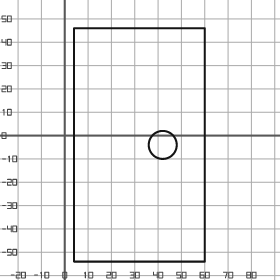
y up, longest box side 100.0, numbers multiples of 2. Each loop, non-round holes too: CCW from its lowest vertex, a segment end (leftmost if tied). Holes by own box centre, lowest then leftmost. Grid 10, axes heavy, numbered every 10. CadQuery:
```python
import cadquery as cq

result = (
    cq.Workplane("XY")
    .moveTo(4.0, -54.0)
    .lineTo(60.0, -54.0)
    .lineTo(60.0, 46.0)
    .lineTo(4.0, 46.0)
    .close()
    .moveTo(42.0, -4.0)
    .circle(6.0)
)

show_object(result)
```